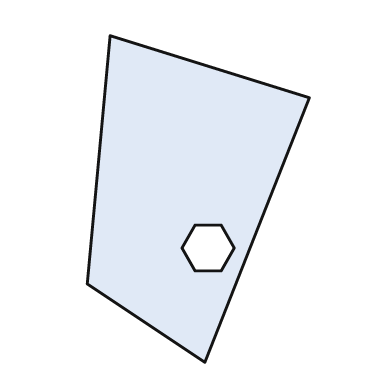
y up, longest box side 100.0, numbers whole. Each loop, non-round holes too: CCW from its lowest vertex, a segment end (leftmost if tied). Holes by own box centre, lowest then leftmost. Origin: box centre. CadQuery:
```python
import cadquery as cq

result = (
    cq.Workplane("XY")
    .moveTo(2.0, -50.0)
    .lineTo(34.0, 31.0)
    .lineTo(-27.0, 50.0)
    .lineTo(-34.0, -26.0)
    .close()
    .moveTo(-1.0, -22.0)
    .lineTo(7.0, -22.0)
    .lineTo(11.0, -15.0)
    .lineTo(7.0, -8.0)
    .lineTo(-1.0, -8.0)
    .lineTo(-5.0, -15.0)
    .close()
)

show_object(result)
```